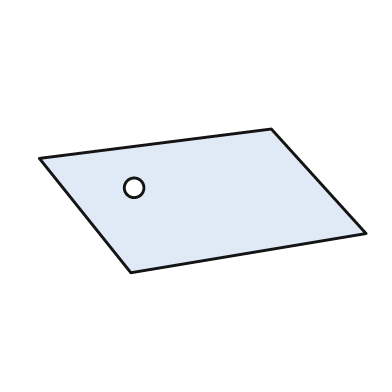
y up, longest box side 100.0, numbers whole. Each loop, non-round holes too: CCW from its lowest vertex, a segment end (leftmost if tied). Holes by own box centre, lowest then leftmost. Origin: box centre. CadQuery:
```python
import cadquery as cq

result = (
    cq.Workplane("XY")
    .moveTo(-22.0, -22.0)
    .lineTo(50.0, -10.0)
    .lineTo(21.0, 22.0)
    .lineTo(-50.0, 13.0)
    .close()
    .moveTo(-21.0, 4.0)
    .circle(3.0)
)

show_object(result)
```